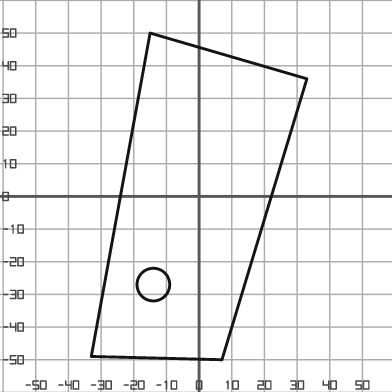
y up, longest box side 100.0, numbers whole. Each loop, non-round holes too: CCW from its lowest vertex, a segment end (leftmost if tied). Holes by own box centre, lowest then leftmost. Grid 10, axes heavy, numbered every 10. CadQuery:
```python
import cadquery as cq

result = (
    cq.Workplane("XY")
    .moveTo(7.0, -50.0)
    .lineTo(33.0, 36.0)
    .lineTo(-15.0, 50.0)
    .lineTo(-33.0, -49.0)
    .close()
    .moveTo(-14.0, -27.0)
    .circle(5.0)
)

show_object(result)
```